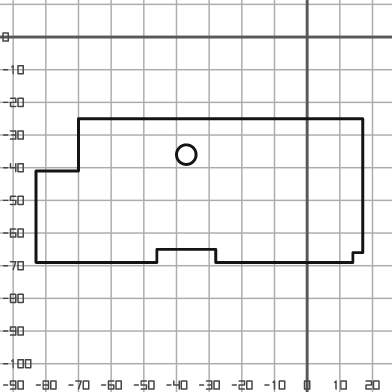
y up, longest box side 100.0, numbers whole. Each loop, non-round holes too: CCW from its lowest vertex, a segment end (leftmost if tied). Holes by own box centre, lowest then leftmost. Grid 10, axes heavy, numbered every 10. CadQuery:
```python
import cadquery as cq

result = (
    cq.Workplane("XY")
    .moveTo(-83.0, -69.0)
    .lineTo(-46.0, -69.0)
    .lineTo(-46.0, -65.0)
    .lineTo(-28.0, -65.0)
    .lineTo(-28.0, -69.0)
    .lineTo(14.0, -69.0)
    .lineTo(14.0, -66.0)
    .lineTo(17.0, -66.0)
    .lineTo(17.0, -25.0)
    .lineTo(-70.0, -25.0)
    .lineTo(-70.0, -41.0)
    .lineTo(-83.0, -41.0)
    .close()
    .moveTo(-37.0, -36.0)
    .circle(3.0)
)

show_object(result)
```